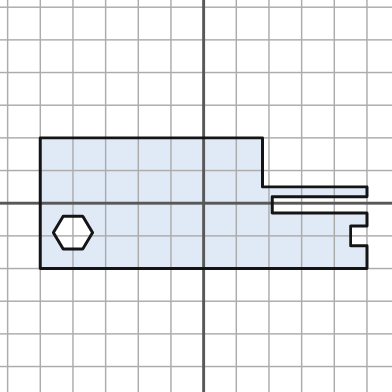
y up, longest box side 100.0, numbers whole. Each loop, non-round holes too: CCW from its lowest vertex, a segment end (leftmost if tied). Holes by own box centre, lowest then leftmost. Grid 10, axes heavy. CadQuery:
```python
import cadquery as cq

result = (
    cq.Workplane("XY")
    .moveTo(-50.0, -20.0)
    .lineTo(50.0, -20.0)
    .lineTo(50.0, -13.0)
    .lineTo(45.0, -13.0)
    .lineTo(45.0, -7.0)
    .lineTo(50.0, -7.0)
    .lineTo(50.0, -3.0)
    .lineTo(21.0, -3.0)
    .lineTo(21.0, 2.0)
    .lineTo(50.0, 2.0)
    .lineTo(50.0, 5.0)
    .lineTo(18.0, 5.0)
    .lineTo(18.0, 20.0)
    .lineTo(-50.0, 20.0)
    .close()
    .moveTo(-43.0, -14.0)
    .lineTo(-37.0, -14.0)
    .lineTo(-34.0, -9.0)
    .lineTo(-37.0, -4.0)
    .lineTo(-43.0, -4.0)
    .lineTo(-46.0, -9.0)
    .close()
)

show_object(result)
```